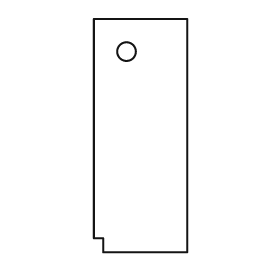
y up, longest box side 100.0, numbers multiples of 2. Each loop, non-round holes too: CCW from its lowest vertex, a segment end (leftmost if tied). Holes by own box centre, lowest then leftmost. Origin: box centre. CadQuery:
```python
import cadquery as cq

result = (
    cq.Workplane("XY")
    .moveTo(-16.0, -50.0)
    .lineTo(20.0, -50.0)
    .lineTo(20.0, 50.0)
    .lineTo(-20.0, 50.0)
    .lineTo(-20.0, -44.0)
    .lineTo(-16.0, -44.0)
    .close()
    .moveTo(-6.0, 36.0)
    .circle(4.0)
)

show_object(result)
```